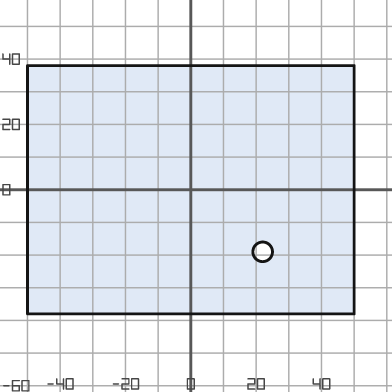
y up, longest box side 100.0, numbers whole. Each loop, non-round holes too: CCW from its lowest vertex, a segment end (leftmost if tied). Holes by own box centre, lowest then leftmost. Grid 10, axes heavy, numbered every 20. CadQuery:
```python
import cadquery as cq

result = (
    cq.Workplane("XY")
    .moveTo(-50.0, -38.0)
    .lineTo(50.0, -38.0)
    .lineTo(50.0, 38.0)
    .lineTo(-50.0, 38.0)
    .close()
    .moveTo(22.0, -19.0)
    .circle(3.0)
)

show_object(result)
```